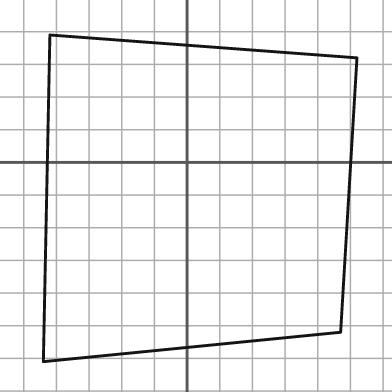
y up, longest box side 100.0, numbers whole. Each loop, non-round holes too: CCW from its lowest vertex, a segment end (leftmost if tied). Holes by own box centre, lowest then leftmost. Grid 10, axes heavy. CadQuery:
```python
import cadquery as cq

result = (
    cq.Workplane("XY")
    .moveTo(-44.0, -61.0)
    .lineTo(47.0, -52.0)
    .lineTo(52.0, 32.0)
    .lineTo(-42.0, 39.0)
    .close()
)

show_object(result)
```